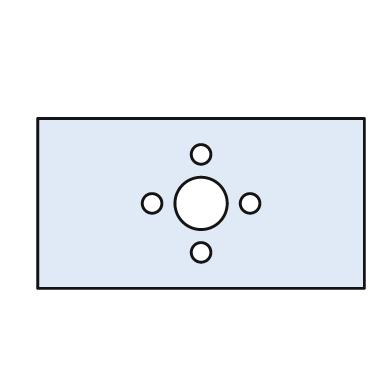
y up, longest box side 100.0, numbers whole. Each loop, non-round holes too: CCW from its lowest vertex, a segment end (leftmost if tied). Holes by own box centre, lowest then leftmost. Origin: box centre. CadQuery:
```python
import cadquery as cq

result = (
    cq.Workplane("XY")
    .moveTo(-50.0, -26.0)
    .lineTo(50.0, -26.0)
    .lineTo(50.0, 26.0)
    .lineTo(-50.0, 26.0)
    .close()
    .moveTo(0.0, -15.0)
    .circle(3.0)
    .moveTo(-15.0, 0.0)
    .circle(3.0)
    .moveTo(0.0, 0.0)
    .circle(8.0)
    .moveTo(15.0, 0.0)
    .circle(3.0)
    .moveTo(0.0, 15.0)
    .circle(3.0)
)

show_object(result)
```